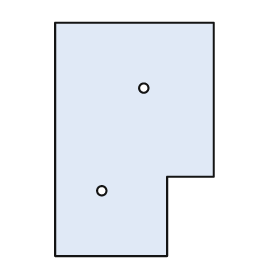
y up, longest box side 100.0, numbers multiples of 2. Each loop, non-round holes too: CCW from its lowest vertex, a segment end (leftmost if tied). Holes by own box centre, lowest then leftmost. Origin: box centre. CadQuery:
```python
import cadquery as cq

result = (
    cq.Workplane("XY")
    .moveTo(-34.0, -50.0)
    .lineTo(14.0, -50.0)
    .lineTo(14.0, -16.0)
    .lineTo(34.0, -16.0)
    .lineTo(34.0, 50.0)
    .lineTo(-34.0, 50.0)
    .close()
    .moveTo(-14.0, -22.0)
    .circle(2.0)
    .moveTo(4.0, 22.0)
    .circle(2.0)
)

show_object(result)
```